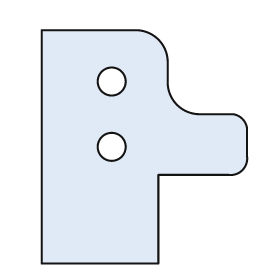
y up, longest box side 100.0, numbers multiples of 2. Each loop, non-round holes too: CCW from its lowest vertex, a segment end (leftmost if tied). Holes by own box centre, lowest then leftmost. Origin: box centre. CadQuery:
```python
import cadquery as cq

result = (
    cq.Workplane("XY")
    .moveTo(-44.0, -50.0)
    .lineTo(6.0, -50.0)
    .lineTo(6.0, -12.0)
    .lineTo(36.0, -12.0)
    .threePointArc((42.0, -10.0), (44.0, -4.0))
    .lineTo(44.0, 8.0)
    .threePointArc((42.0, 12.0), (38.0, 14.0))
    .lineTo(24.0, 14.0)
    .threePointArc((14.0, 18.0), (10.0, 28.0))
    .lineTo(10.0, 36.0)
    .threePointArc((6.0, 46.0), (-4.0, 50.0))
    .lineTo(-44.0, 50.0)
    .close()
    .moveTo(-14.0, 0.0)
    .circle(6.0)
    .moveTo(-14.0, 28.0)
    .circle(6.0)
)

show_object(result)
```